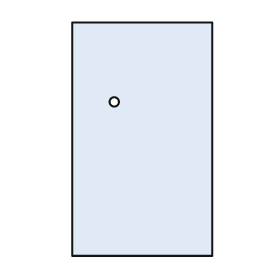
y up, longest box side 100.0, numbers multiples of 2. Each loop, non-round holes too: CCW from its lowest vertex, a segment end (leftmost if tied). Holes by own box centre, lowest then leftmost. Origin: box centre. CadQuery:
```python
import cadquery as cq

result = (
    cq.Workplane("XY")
    .moveTo(-30.0, -50.0)
    .lineTo(30.0, -50.0)
    .lineTo(30.0, 50.0)
    .lineTo(-30.0, 50.0)
    .close()
    .moveTo(-12.0, 16.0)
    .circle(2.0)
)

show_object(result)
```